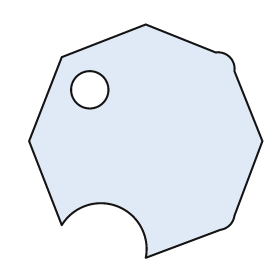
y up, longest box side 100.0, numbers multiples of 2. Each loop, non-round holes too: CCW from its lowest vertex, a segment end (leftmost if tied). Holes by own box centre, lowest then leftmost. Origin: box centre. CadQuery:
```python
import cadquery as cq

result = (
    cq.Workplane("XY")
    .moveTo(0.0, -50.0)
    .lineTo(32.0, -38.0)
    .threePointArc((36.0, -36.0), (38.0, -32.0))
    .lineTo(50.0, 0.0)
    .lineTo(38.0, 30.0)
    .threePointArc((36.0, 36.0), (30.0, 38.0))
    .lineTo(0.0, 50.0)
    .lineTo(-36.0, 36.0)
    .lineTo(-50.0, 0.0)
    .lineTo(-36.0, -36.0)
    .threePointArc((-12.0, -28.0), (0.0, -50.0))
    .close()
    .moveTo(-24.0, 22.0)
    .circle(8.0)
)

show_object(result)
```